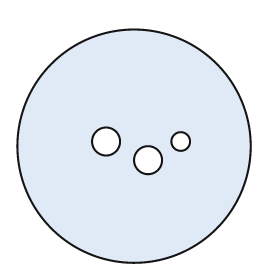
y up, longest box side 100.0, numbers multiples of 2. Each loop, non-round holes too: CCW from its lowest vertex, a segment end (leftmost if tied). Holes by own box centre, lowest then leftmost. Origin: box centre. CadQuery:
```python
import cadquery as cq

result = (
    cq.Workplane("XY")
    .moveTo(0.0, 0.0)
    .circle(50.0)
    .moveTo(6.0, -6.0)
    .circle(6.0)
    .moveTo(-12.0, 2.0)
    .circle(6.0)
    .moveTo(20.0, 2.0)
    .circle(4.0)
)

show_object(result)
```